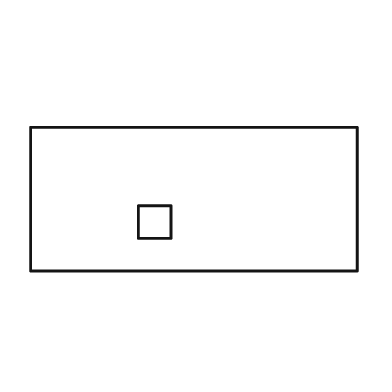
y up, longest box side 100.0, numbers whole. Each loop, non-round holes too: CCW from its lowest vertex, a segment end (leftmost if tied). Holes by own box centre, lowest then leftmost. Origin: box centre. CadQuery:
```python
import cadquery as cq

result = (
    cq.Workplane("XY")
    .moveTo(-50.0, -22.0)
    .lineTo(50.0, -22.0)
    .lineTo(50.0, 22.0)
    .lineTo(-50.0, 22.0)
    .close()
    .moveTo(-17.0, -12.0)
    .lineTo(-7.0, -12.0)
    .lineTo(-7.0, -2.0)
    .lineTo(-17.0, -2.0)
    .close()
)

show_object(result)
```